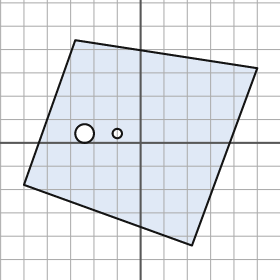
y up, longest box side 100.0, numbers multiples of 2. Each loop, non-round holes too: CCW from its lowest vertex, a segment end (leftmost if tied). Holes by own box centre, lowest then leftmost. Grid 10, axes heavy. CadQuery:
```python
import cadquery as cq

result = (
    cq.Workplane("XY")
    .moveTo(22.0, -44.0)
    .lineTo(50.0, 32.0)
    .lineTo(-28.0, 44.0)
    .lineTo(-50.0, -18.0)
    .close()
    .moveTo(-24.0, 4.0)
    .circle(4.0)
    .moveTo(-10.0, 4.0)
    .circle(2.0)
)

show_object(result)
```